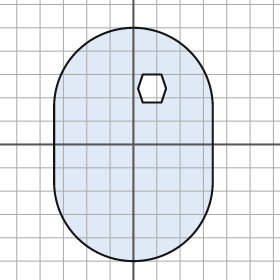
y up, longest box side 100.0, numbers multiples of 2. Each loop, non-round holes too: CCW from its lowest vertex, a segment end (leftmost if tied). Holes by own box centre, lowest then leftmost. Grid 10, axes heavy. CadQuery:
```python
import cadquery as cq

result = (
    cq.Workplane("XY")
    .moveTo(-34.0, -16.0)
    .threePointArc((0.0, -50.0), (34.0, -16.0))
    .lineTo(34.0, 16.0)
    .threePointArc((0.0, 50.0), (-34.0, 16.0))
    .close()
    .moveTo(4.0, 18.0)
    .lineTo(12.0, 18.0)
    .lineTo(14.0, 24.0)
    .lineTo(12.0, 30.0)
    .lineTo(4.0, 30.0)
    .lineTo(2.0, 24.0)
    .close()
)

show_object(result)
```